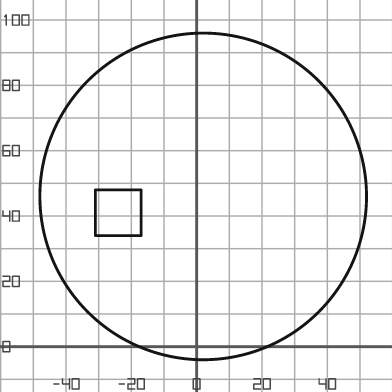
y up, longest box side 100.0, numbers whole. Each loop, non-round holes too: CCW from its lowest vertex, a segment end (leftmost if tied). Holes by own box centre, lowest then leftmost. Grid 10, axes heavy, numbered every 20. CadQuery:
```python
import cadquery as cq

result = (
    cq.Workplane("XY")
    .moveTo(2.0, 46.0)
    .circle(50.0)
    .moveTo(-31.0, 34.0)
    .lineTo(-17.0, 34.0)
    .lineTo(-17.0, 48.0)
    .lineTo(-31.0, 48.0)
    .close()
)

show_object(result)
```